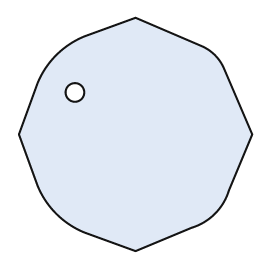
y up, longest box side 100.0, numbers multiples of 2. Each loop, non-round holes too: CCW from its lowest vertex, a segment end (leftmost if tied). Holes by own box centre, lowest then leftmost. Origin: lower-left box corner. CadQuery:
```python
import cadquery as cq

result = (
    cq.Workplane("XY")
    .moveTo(50.0, 0.0)
    .lineTo(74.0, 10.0)
    .threePointArc((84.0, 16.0), (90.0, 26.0))
    .lineTo(100.0, 50.0)
    .lineTo(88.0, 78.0)
    .threePointArc((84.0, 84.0), (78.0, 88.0))
    .lineTo(50.0, 100.0)
    .lineTo(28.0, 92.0)
    .threePointArc((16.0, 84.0), (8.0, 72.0))
    .lineTo(0.0, 50.0)
    .lineTo(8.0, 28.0)
    .threePointArc((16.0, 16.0), (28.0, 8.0))
    .close()
    .moveTo(24.0, 68.0)
    .circle(4.0)
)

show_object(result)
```